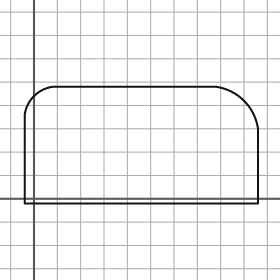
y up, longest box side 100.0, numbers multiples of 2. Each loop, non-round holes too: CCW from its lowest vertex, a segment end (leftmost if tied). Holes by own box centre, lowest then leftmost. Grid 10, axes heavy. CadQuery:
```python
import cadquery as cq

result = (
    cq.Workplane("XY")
    .moveTo(-4.0, -2.0)
    .lineTo(96.0, -2.0)
    .lineTo(96.0, 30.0)
    .threePointArc((90.0, 42.0), (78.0, 48.0))
    .lineTo(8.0, 48.0)
    .threePointArc((0.0, 44.0), (-4.0, 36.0))
    .close()
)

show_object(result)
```